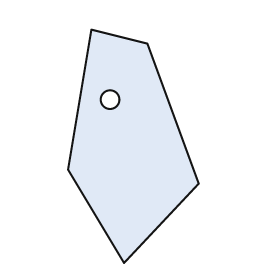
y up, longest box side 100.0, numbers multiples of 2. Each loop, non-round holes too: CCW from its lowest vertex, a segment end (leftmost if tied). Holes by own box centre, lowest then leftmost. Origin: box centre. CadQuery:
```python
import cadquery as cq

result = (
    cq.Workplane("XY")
    .moveTo(-4.0, -50.0)
    .lineTo(28.0, -16.0)
    .lineTo(6.0, 44.0)
    .lineTo(-18.0, 50.0)
    .lineTo(-28.0, -10.0)
    .close()
    .moveTo(-10.0, 20.0)
    .circle(4.0)
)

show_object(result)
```